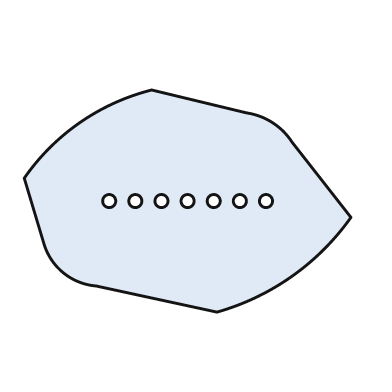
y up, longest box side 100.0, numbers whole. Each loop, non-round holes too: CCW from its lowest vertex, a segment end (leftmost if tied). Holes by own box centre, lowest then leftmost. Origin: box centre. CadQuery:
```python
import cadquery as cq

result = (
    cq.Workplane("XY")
    .moveTo(9.0, -34.0)
    .threePointArc((32.0, -23.0), (50.0, -5.0))
    .lineTo(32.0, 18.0)
    .threePointArc((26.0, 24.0), (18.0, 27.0))
    .lineTo(-11.0, 34.0)
    .threePointArc((-33.0, 24.0), (-50.0, 7.0))
    .lineTo(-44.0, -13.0)
    .threePointArc((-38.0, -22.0), (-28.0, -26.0))
    .close()
    .moveTo(-24.0, 0.0)
    .circle(2.0)
    .moveTo(-16.0, 0.0)
    .circle(2.0)
    .moveTo(-8.0, 0.0)
    .circle(2.0)
    .moveTo(0.0, 0.0)
    .circle(2.0)
    .moveTo(8.0, 0.0)
    .circle(2.0)
    .moveTo(16.0, 0.0)
    .circle(2.0)
    .moveTo(24.0, 0.0)
    .circle(2.0)
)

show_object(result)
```